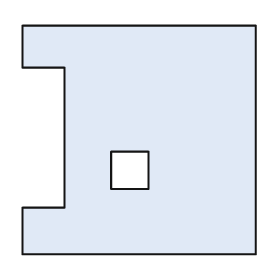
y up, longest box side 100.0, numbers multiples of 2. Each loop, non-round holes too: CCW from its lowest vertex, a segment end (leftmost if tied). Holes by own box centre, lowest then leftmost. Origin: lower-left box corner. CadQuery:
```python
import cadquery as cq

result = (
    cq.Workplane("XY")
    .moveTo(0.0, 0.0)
    .lineTo(100.0, 0.0)
    .lineTo(100.0, 98.0)
    .lineTo(0.0, 98.0)
    .lineTo(0.0, 80.0)
    .lineTo(18.0, 80.0)
    .lineTo(18.0, 20.0)
    .lineTo(0.0, 20.0)
    .close()
    .moveTo(38.0, 28.0)
    .lineTo(54.0, 28.0)
    .lineTo(54.0, 44.0)
    .lineTo(38.0, 44.0)
    .close()
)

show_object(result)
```